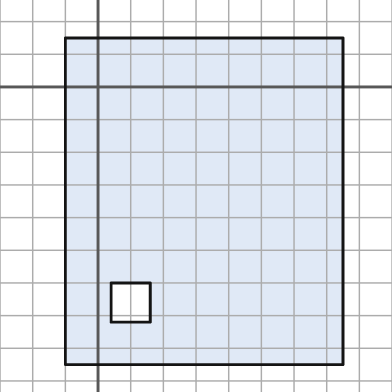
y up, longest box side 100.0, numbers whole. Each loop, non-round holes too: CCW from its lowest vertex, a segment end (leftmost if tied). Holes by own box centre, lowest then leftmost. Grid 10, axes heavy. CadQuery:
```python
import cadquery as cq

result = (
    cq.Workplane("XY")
    .moveTo(-10.0, -85.0)
    .lineTo(75.0, -85.0)
    .lineTo(75.0, 15.0)
    .lineTo(-10.0, 15.0)
    .close()
    .moveTo(4.0, -72.0)
    .lineTo(16.0, -72.0)
    .lineTo(16.0, -60.0)
    .lineTo(4.0, -60.0)
    .close()
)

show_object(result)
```